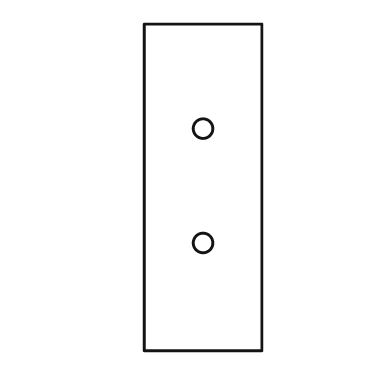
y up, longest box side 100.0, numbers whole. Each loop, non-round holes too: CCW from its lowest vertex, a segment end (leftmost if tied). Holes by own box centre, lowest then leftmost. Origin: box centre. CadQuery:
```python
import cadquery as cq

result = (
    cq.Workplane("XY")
    .moveTo(-18.0, -50.0)
    .lineTo(18.0, -50.0)
    .lineTo(18.0, 50.0)
    .lineTo(-18.0, 50.0)
    .close()
    .moveTo(0.0, -17.0)
    .circle(3.0)
    .moveTo(0.0, 18.0)
    .circle(3.0)
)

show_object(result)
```